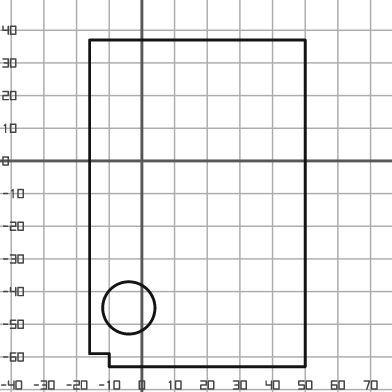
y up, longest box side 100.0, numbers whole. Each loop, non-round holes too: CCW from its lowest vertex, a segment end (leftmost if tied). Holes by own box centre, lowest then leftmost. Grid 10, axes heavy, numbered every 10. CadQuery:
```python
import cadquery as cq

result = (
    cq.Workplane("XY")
    .moveTo(-10.0, -63.0)
    .lineTo(50.0, -63.0)
    .lineTo(50.0, 37.0)
    .lineTo(-16.0, 37.0)
    .lineTo(-16.0, -59.0)
    .lineTo(-10.0, -59.0)
    .close()
    .moveTo(-4.0, -45.0)
    .circle(8.0)
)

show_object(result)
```